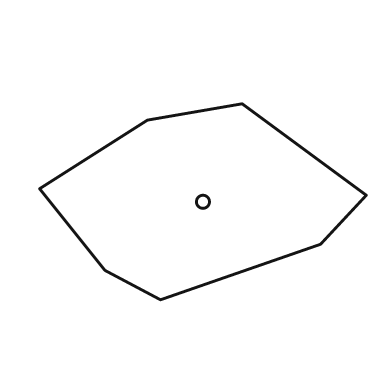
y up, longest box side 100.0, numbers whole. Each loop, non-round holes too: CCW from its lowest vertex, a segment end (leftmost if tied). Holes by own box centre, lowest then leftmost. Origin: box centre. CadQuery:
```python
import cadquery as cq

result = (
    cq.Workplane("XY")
    .moveTo(-13.0, -30.0)
    .lineTo(36.0, -13.0)
    .lineTo(50.0, 2.0)
    .lineTo(12.0, 30.0)
    .lineTo(-17.0, 25.0)
    .lineTo(-50.0, 4.0)
    .lineTo(-30.0, -21.0)
    .close()
    .moveTo(0.0, 0.0)
    .circle(2.0)
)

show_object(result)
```